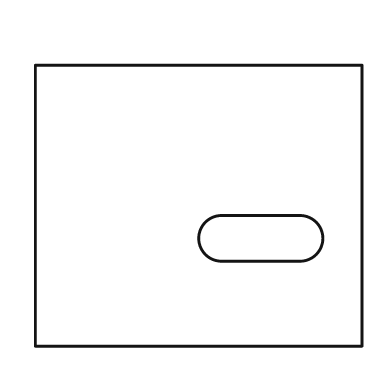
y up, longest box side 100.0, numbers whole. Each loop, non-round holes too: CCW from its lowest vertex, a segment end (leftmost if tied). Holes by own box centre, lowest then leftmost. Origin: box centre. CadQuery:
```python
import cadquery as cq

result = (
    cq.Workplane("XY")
    .moveTo(-50.0, -43.0)
    .lineTo(50.0, -43.0)
    .lineTo(50.0, 43.0)
    .lineTo(-50.0, 43.0)
    .close()
    .moveTo(7.0, -17.0)
    .lineTo(31.0, -17.0)
    .threePointArc((38.0, -10.0), (31.0, -3.0))
    .lineTo(7.0, -3.0)
    .threePointArc((0.0, -10.0), (7.0, -17.0))
    .close()
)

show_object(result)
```